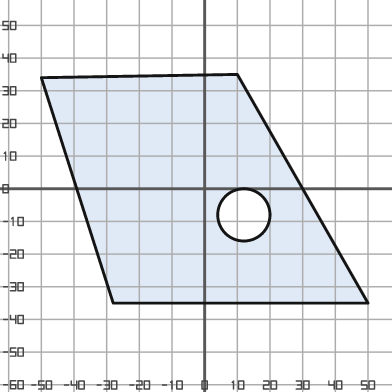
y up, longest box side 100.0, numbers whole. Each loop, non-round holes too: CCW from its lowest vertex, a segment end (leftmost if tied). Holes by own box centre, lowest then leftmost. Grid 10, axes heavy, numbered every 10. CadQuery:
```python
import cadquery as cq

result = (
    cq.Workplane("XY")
    .moveTo(-28.0, -35.0)
    .lineTo(50.0, -35.0)
    .lineTo(10.0, 35.0)
    .lineTo(-50.0, 34.0)
    .close()
    .moveTo(12.0, -8.0)
    .circle(8.0)
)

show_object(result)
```